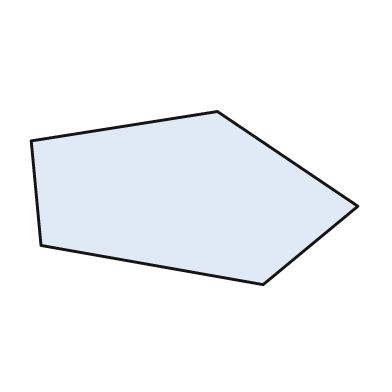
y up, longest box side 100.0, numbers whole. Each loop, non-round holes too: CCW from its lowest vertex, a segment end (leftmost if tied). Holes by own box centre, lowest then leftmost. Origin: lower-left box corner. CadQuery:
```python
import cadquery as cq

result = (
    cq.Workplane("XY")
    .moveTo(71.0, 0.0)
    .lineTo(100.0, 24.0)
    .lineTo(57.0, 53.0)
    .lineTo(0.0, 44.0)
    .lineTo(3.0, 12.0)
    .close()
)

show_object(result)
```